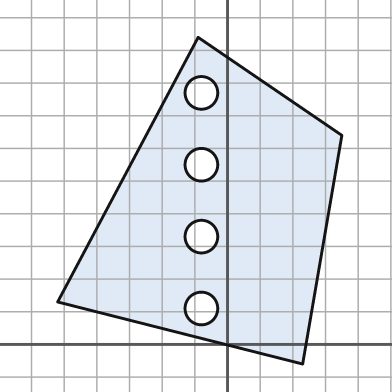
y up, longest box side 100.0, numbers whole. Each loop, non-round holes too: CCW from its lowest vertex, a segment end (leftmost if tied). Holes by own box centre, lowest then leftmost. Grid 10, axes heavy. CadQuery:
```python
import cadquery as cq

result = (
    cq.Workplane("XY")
    .moveTo(23.0, -6.0)
    .lineTo(35.0, 64.0)
    .lineTo(-9.0, 94.0)
    .lineTo(-52.0, 13.0)
    .close()
    .moveTo(-8.0, 11.0)
    .circle(5.0)
    .moveTo(-8.0, 33.0)
    .circle(5.0)
    .moveTo(-8.0, 55.0)
    .circle(5.0)
    .moveTo(-8.0, 77.0)
    .circle(5.0)
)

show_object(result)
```